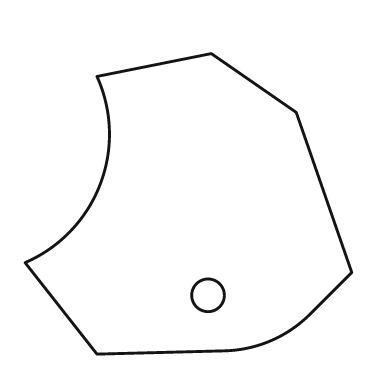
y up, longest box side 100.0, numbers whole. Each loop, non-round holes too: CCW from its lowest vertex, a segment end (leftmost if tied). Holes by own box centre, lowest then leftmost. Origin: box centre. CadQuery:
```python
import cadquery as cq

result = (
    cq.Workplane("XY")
    .moveTo(-28.0, -46.0)
    .lineTo(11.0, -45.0)
    .threePointArc((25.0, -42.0), (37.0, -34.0))
    .lineTo(50.0, -21.0)
    .lineTo(33.0, 28.0)
    .lineTo(7.0, 46.0)
    .lineTo(-28.0, 39.0)
    .threePointArc((-27.0, 6.0), (-50.0, -18.0))
    .close()
    .moveTo(6.0, -28.0)
    .circle(5.0)
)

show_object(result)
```